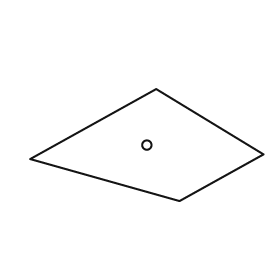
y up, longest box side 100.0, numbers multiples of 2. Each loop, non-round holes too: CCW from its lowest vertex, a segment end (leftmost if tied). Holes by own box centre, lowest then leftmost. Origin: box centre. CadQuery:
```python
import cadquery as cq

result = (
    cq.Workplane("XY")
    .moveTo(14.0, -24.0)
    .lineTo(50.0, -4.0)
    .lineTo(4.0, 24.0)
    .lineTo(-50.0, -6.0)
    .close()
    .moveTo(0.0, 0.0)
    .circle(2.0)
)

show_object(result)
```